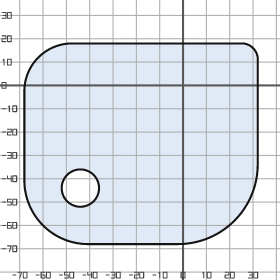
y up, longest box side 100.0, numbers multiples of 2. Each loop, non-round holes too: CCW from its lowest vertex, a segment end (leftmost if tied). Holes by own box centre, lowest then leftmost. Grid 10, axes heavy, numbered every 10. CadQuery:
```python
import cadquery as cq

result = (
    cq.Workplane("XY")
    .moveTo(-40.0, -68.0)
    .lineTo(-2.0, -68.0)
    .threePointArc((22.0, -58.0), (32.0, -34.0))
    .lineTo(32.0, 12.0)
    .threePointArc((30.0, 16.0), (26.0, 18.0))
    .lineTo(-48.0, 18.0)
    .threePointArc((-62.0, 12.0), (-68.0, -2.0))
    .lineTo(-68.0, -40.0)
    .threePointArc((-60.0, -60.0), (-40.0, -68.0))
    .close()
    .moveTo(-44.0, -44.0)
    .circle(8.0)
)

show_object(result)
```